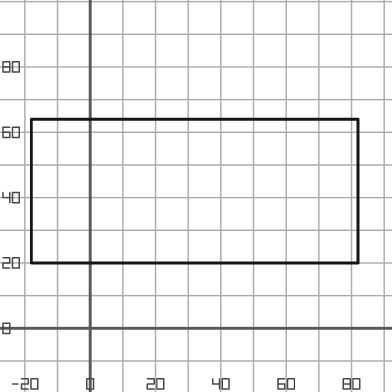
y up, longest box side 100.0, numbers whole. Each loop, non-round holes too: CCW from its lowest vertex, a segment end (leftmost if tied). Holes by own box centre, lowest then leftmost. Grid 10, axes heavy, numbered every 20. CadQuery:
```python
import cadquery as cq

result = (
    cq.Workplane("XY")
    .moveTo(-18.0, 20.0)
    .lineTo(82.0, 20.0)
    .lineTo(82.0, 64.0)
    .lineTo(-18.0, 64.0)
    .close()
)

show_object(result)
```